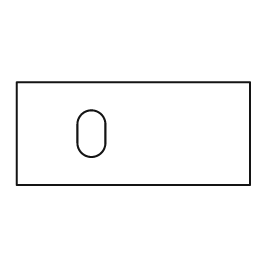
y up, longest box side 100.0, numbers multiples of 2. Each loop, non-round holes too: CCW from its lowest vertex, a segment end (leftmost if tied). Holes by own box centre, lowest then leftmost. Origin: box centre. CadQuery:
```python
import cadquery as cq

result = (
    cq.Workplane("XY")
    .moveTo(-50.0, -22.0)
    .lineTo(50.0, -22.0)
    .lineTo(50.0, 22.0)
    .lineTo(-50.0, 22.0)
    .close()
    .moveTo(-24.0, -4.0)
    .threePointArc((-18.0, -10.0), (-12.0, -4.0))
    .lineTo(-12.0, 4.0)
    .threePointArc((-18.0, 10.0), (-24.0, 4.0))
    .close()
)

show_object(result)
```